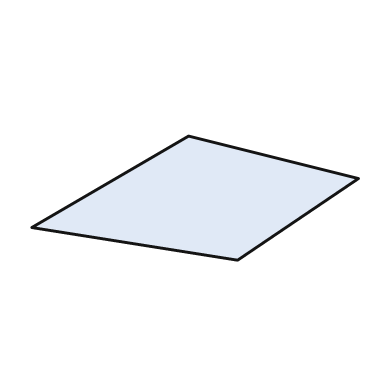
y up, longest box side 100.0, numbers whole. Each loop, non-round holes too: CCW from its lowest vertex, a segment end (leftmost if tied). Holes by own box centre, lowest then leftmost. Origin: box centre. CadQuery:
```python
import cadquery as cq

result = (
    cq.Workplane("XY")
    .moveTo(13.0, -19.0)
    .lineTo(50.0, 6.0)
    .lineTo(-2.0, 19.0)
    .lineTo(-50.0, -9.0)
    .close()
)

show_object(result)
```